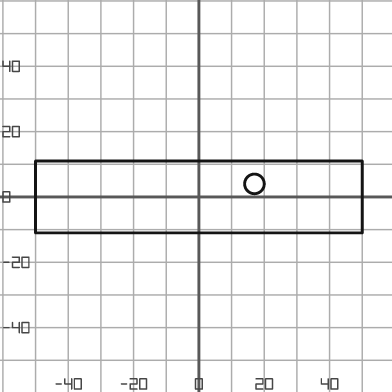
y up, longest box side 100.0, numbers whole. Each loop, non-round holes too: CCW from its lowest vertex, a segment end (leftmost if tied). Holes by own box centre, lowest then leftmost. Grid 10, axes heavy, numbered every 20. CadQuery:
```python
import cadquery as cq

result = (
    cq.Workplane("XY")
    .moveTo(-50.0, -11.0)
    .lineTo(50.0, -11.0)
    .lineTo(50.0, 11.0)
    .lineTo(-50.0, 11.0)
    .close()
    .moveTo(17.0, 4.0)
    .circle(3.0)
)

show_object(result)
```